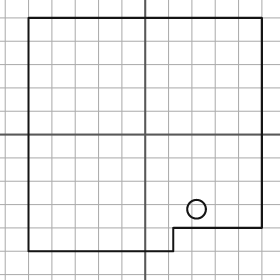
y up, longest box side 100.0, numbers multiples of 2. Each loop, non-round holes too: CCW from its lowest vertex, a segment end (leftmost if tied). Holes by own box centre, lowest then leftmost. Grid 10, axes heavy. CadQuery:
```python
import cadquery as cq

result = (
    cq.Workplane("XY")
    .moveTo(-50.0, -50.0)
    .lineTo(12.0, -50.0)
    .lineTo(12.0, -40.0)
    .lineTo(50.0, -40.0)
    .lineTo(50.0, 50.0)
    .lineTo(-50.0, 50.0)
    .close()
    .moveTo(22.0, -32.0)
    .circle(4.0)
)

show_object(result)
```